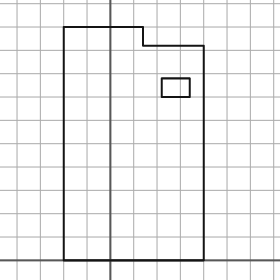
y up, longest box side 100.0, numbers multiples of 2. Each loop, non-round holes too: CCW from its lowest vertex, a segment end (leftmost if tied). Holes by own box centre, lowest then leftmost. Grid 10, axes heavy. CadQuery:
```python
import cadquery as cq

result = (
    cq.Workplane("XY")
    .moveTo(-20.0, 0.0)
    .lineTo(40.0, 0.0)
    .lineTo(40.0, 92.0)
    .lineTo(14.0, 92.0)
    .lineTo(14.0, 100.0)
    .lineTo(-20.0, 100.0)
    .close()
    .moveTo(22.0, 70.0)
    .lineTo(34.0, 70.0)
    .lineTo(34.0, 78.0)
    .lineTo(22.0, 78.0)
    .close()
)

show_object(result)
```